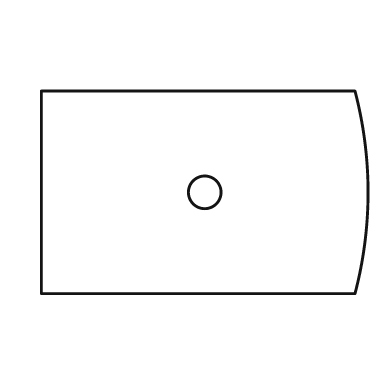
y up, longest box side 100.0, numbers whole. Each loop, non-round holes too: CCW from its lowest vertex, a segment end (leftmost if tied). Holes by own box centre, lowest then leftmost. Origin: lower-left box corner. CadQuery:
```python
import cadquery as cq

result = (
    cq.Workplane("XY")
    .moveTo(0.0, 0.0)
    .lineTo(96.0, 0.0)
    .threePointArc((100.0, 31.0), (96.0, 62.0))
    .lineTo(0.0, 62.0)
    .close()
    .moveTo(50.0, 31.0)
    .circle(5.0)
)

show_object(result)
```